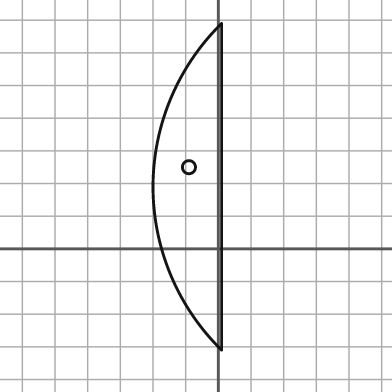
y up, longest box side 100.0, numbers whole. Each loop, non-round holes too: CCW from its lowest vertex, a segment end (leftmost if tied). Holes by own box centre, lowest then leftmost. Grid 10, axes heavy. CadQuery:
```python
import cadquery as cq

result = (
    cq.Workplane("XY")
    .moveTo(1.0, -31.0)
    .lineTo(1.0, 69.0)
    .threePointArc((-20.0, 19.0), (1.0, -31.0))
    .close()
    .moveTo(-9.0, 25.0)
    .circle(2.0)
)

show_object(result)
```